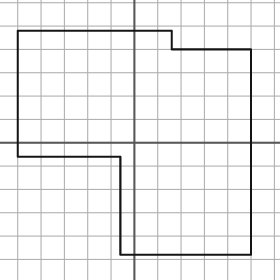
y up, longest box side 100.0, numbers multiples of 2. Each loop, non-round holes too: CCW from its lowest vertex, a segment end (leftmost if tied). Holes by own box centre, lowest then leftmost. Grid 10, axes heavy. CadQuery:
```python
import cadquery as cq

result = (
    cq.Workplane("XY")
    .moveTo(-6.0, -48.0)
    .lineTo(50.0, -48.0)
    .lineTo(50.0, 40.0)
    .lineTo(16.0, 40.0)
    .lineTo(16.0, 48.0)
    .lineTo(-50.0, 48.0)
    .lineTo(-50.0, -6.0)
    .lineTo(-6.0, -6.0)
    .close()
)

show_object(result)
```